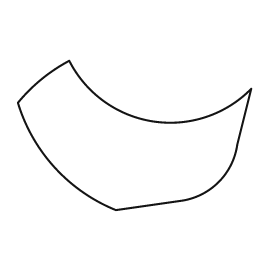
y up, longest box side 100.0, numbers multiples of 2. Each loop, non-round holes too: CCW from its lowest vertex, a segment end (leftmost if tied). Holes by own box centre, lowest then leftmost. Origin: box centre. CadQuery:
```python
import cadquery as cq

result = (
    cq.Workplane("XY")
    .moveTo(-8.0, -32.0)
    .lineTo(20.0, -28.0)
    .threePointArc((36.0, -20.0), (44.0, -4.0))
    .lineTo(50.0, 20.0)
    .threePointArc((8.0, 6.0), (-28.0, 32.0))
    .threePointArc((-40.0, 24.0), (-50.0, 14.0))
    .threePointArc((-34.0, -14.0), (-8.0, -32.0))
    .close()
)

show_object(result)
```